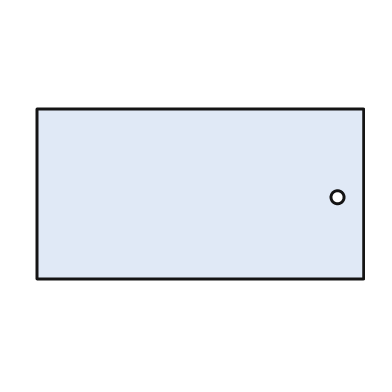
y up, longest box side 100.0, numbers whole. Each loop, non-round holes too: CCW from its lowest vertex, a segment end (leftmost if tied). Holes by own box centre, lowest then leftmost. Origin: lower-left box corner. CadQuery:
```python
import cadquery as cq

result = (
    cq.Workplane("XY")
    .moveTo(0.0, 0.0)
    .lineTo(100.0, 0.0)
    .lineTo(100.0, 52.0)
    .lineTo(0.0, 52.0)
    .close()
    .moveTo(92.0, 25.0)
    .circle(2.0)
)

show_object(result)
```